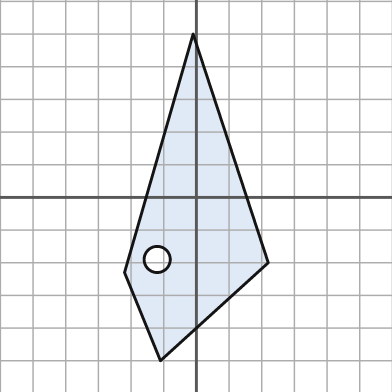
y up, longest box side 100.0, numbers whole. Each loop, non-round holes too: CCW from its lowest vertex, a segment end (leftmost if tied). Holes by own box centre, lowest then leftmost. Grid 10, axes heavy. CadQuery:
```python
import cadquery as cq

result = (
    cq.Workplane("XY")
    .moveTo(-11.0, -50.0)
    .lineTo(22.0, -20.0)
    .lineTo(-1.0, 50.0)
    .lineTo(-22.0, -23.0)
    .close()
    .moveTo(-12.0, -19.0)
    .circle(4.0)
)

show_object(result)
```